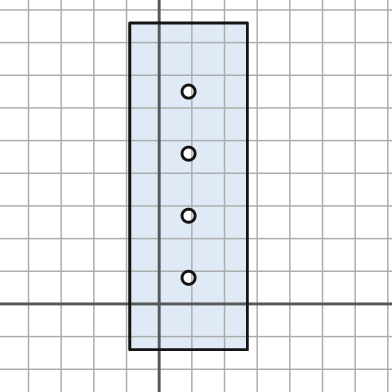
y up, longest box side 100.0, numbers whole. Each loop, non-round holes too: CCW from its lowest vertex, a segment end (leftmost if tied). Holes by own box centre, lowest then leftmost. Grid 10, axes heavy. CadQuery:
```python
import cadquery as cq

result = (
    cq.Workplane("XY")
    .moveTo(-9.0, -14.0)
    .lineTo(27.0, -14.0)
    .lineTo(27.0, 86.0)
    .lineTo(-9.0, 86.0)
    .close()
    .moveTo(9.0, 8.0)
    .circle(2.0)
    .moveTo(9.0, 27.0)
    .circle(2.0)
    .moveTo(9.0, 46.0)
    .circle(2.0)
    .moveTo(9.0, 65.0)
    .circle(2.0)
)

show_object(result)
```